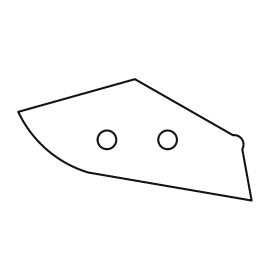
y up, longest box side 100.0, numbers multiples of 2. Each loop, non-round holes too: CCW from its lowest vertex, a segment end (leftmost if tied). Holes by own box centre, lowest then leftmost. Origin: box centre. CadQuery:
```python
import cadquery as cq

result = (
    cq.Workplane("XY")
    .moveTo(50.0, -26.0)
    .lineTo(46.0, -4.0)
    .threePointArc((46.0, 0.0), (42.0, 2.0))
    .lineTo(0.0, 26.0)
    .lineTo(-50.0, 12.0)
    .threePointArc((-38.0, -4.0), (-20.0, -14.0))
    .close()
    .moveTo(-12.0, 0.0)
    .circle(4.0)
    .moveTo(14.0, 0.0)
    .circle(4.0)
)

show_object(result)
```